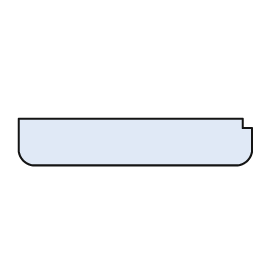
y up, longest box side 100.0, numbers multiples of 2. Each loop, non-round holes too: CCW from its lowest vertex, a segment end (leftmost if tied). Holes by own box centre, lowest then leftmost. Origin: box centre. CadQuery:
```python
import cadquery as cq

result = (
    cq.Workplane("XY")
    .moveTo(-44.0, -10.0)
    .lineTo(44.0, -10.0)
    .threePointArc((48.0, -8.0), (50.0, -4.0))
    .lineTo(50.0, 6.0)
    .lineTo(46.0, 6.0)
    .lineTo(46.0, 10.0)
    .lineTo(-50.0, 10.0)
    .lineTo(-50.0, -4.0)
    .threePointArc((-48.0, -8.0), (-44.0, -10.0))
    .close()
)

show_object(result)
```